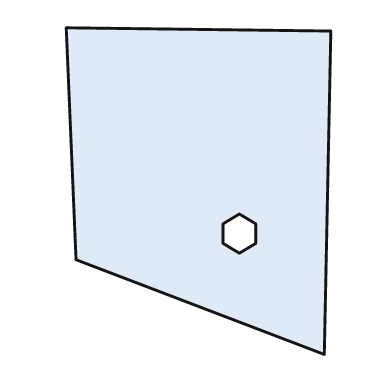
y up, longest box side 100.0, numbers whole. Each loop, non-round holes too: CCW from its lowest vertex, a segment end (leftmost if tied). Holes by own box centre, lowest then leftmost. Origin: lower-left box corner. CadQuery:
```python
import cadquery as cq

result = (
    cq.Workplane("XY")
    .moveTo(79.0, 0.0)
    .lineTo(81.0, 99.0)
    .lineTo(0.0, 100.0)
    .lineTo(3.0, 29.0)
    .close()
    .moveTo(53.0, 31.0)
    .lineTo(58.0, 34.0)
    .lineTo(58.0, 40.0)
    .lineTo(53.0, 43.0)
    .lineTo(48.0, 40.0)
    .lineTo(48.0, 34.0)
    .close()
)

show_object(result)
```